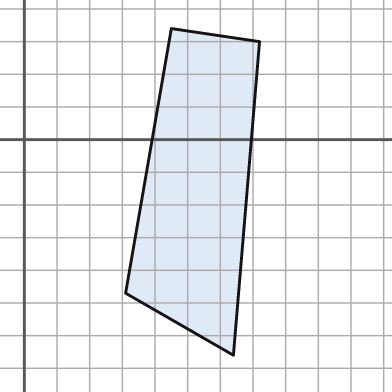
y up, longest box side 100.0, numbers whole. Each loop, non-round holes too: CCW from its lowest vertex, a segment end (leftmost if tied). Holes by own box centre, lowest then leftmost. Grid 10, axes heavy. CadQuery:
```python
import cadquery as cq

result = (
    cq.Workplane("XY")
    .moveTo(64.0, -66.0)
    .lineTo(72.0, 30.0)
    .lineTo(45.0, 34.0)
    .lineTo(31.0, -47.0)
    .close()
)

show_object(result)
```